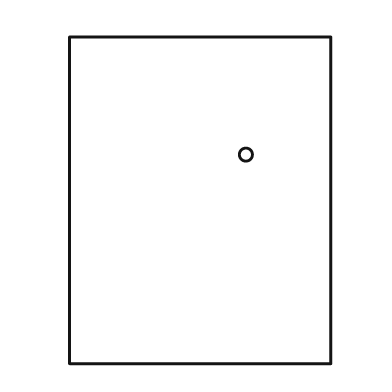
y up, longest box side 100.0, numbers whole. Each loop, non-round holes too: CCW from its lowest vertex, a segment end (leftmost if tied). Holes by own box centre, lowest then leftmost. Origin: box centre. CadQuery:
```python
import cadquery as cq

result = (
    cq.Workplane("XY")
    .moveTo(-40.0, -50.0)
    .lineTo(40.0, -50.0)
    .lineTo(40.0, 50.0)
    .lineTo(-40.0, 50.0)
    .close()
    .moveTo(14.0, 14.0)
    .circle(2.0)
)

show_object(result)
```